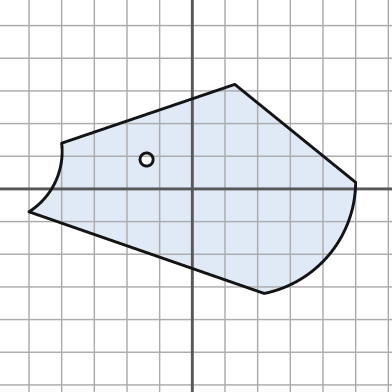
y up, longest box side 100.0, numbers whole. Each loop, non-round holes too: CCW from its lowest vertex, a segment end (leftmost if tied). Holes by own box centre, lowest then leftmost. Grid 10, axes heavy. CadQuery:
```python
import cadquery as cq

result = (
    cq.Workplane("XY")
    .moveTo(22.0, -32.0)
    .threePointArc((42.0, -20.0), (50.0, 2.0))
    .lineTo(13.0, 32.0)
    .lineTo(-40.0, 14.0)
    .threePointArc((-42.0, 2.0), (-50.0, -7.0))
    .close()
    .moveTo(-14.0, 9.0)
    .circle(2.0)
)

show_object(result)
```